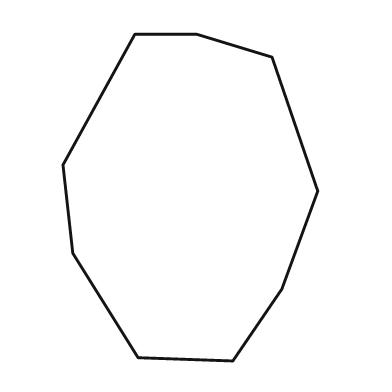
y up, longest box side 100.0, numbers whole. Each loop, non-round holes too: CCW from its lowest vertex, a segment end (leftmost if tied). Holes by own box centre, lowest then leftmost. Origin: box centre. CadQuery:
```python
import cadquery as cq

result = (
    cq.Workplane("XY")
    .moveTo(13.0, -50.0)
    .lineTo(28.0, -28.0)
    .lineTo(39.0, 2.0)
    .lineTo(25.0, 43.0)
    .lineTo(2.0, 50.0)
    .lineTo(-17.0, 50.0)
    .lineTo(-39.0, 10.0)
    .lineTo(-36.0, -17.0)
    .lineTo(-16.0, -49.0)
    .close()
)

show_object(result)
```